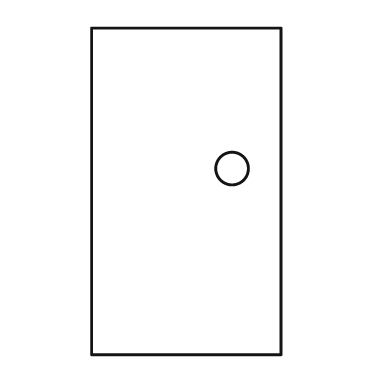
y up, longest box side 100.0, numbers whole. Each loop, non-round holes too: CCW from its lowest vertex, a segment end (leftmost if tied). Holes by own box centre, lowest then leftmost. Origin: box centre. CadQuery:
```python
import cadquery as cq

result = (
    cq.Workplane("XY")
    .moveTo(-29.0, -50.0)
    .lineTo(29.0, -50.0)
    .lineTo(29.0, 50.0)
    .lineTo(-29.0, 50.0)
    .close()
    .moveTo(14.0, 7.0)
    .circle(5.0)
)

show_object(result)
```